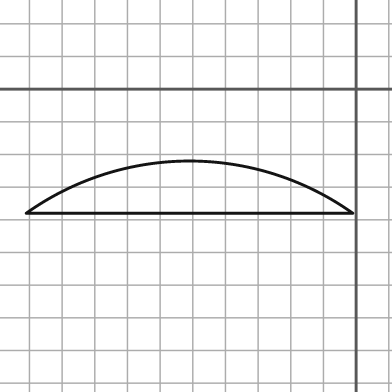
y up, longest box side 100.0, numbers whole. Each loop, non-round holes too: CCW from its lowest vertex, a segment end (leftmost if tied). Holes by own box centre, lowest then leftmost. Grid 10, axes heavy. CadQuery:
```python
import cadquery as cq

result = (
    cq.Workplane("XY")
    .moveTo(-101.0, -38.0)
    .lineTo(-1.0, -38.0)
    .threePointArc((-51.0, -22.0), (-101.0, -38.0))
    .close()
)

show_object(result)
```